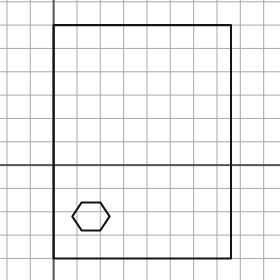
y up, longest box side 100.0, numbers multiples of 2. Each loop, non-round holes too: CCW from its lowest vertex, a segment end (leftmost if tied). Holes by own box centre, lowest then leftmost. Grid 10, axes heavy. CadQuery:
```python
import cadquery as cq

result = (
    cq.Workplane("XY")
    .moveTo(0.0, -40.0)
    .lineTo(76.0, -40.0)
    .lineTo(76.0, 60.0)
    .lineTo(0.0, 60.0)
    .close()
    .moveTo(12.0, -28.0)
    .lineTo(20.0, -28.0)
    .lineTo(24.0, -22.0)
    .lineTo(20.0, -16.0)
    .lineTo(12.0, -16.0)
    .lineTo(8.0, -22.0)
    .close()
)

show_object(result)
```